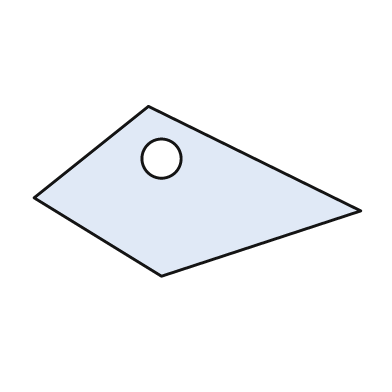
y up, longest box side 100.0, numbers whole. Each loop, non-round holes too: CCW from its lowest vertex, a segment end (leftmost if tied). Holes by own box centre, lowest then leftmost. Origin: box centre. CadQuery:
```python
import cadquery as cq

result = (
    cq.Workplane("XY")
    .moveTo(-11.0, -26.0)
    .lineTo(50.0, -6.0)
    .lineTo(-15.0, 26.0)
    .lineTo(-50.0, -2.0)
    .close()
    .moveTo(-11.0, 10.0)
    .circle(6.0)
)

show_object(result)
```